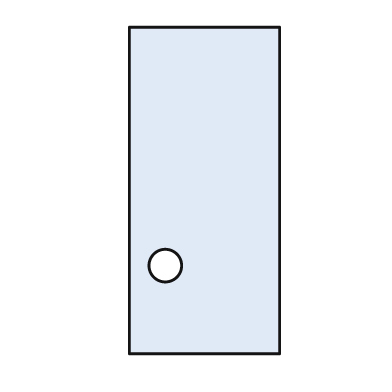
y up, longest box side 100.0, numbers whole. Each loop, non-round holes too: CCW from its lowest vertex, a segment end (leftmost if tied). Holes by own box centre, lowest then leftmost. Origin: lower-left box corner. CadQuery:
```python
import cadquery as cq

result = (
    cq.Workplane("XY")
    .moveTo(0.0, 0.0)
    .lineTo(46.0, 0.0)
    .lineTo(46.0, 100.0)
    .lineTo(0.0, 100.0)
    .close()
    .moveTo(11.0, 27.0)
    .circle(5.0)
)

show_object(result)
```